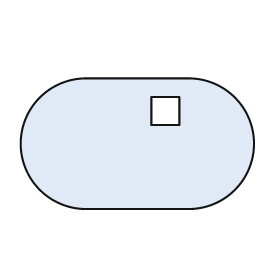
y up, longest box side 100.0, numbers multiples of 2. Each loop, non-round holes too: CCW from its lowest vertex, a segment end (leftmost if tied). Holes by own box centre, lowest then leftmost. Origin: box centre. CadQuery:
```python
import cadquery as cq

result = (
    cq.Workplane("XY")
    .moveTo(-22.0, -28.0)
    .lineTo(22.0, -28.0)
    .threePointArc((50.0, 0.0), (22.0, 28.0))
    .lineTo(-22.0, 28.0)
    .threePointArc((-50.0, 0.0), (-22.0, -28.0))
    .close()
    .moveTo(6.0, 8.0)
    .lineTo(18.0, 8.0)
    .lineTo(18.0, 20.0)
    .lineTo(6.0, 20.0)
    .close()
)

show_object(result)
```